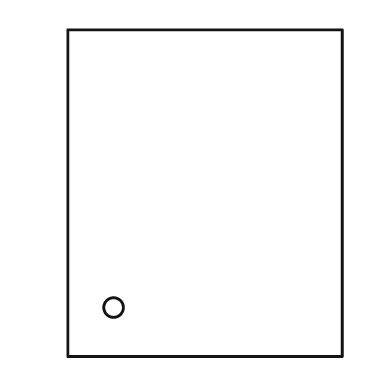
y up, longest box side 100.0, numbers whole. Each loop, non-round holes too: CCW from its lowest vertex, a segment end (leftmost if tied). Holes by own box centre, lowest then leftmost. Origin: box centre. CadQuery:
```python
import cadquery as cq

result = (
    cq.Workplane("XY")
    .moveTo(-42.0, -50.0)
    .lineTo(42.0, -50.0)
    .lineTo(42.0, 50.0)
    .lineTo(-42.0, 50.0)
    .close()
    .moveTo(-28.0, -35.0)
    .circle(3.0)
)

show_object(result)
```